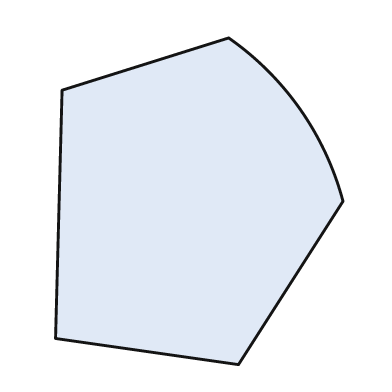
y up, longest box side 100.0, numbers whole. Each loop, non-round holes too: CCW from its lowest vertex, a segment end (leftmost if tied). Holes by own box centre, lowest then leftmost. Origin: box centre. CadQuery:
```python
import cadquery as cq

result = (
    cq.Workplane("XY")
    .moveTo(12.0, -50.0)
    .lineTo(44.0, 0.0)
    .threePointArc((31.0, 28.0), (9.0, 50.0))
    .lineTo(-42.0, 34.0)
    .lineTo(-44.0, -42.0)
    .close()
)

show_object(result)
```